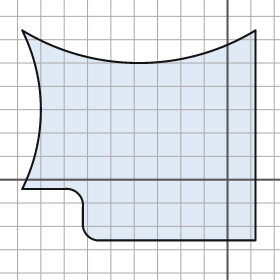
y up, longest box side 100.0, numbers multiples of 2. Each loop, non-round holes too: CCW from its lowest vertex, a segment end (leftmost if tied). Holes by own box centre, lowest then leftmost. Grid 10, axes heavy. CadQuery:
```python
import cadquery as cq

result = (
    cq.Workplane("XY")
    .moveTo(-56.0, -26.0)
    .lineTo(12.0, -26.0)
    .lineTo(12.0, 64.0)
    .threePointArc((-38.0, 50.0), (-88.0, 64.0))
    .threePointArc((-80.0, 30.0), (-88.0, -4.0))
    .lineTo(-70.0, -4.0)
    .threePointArc((-64.0, -6.0), (-62.0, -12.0))
    .lineTo(-62.0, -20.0)
    .threePointArc((-60.0, -24.0), (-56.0, -26.0))
    .close()
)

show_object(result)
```